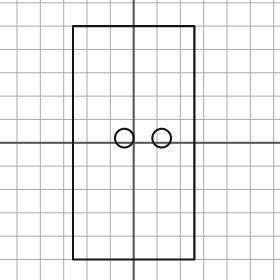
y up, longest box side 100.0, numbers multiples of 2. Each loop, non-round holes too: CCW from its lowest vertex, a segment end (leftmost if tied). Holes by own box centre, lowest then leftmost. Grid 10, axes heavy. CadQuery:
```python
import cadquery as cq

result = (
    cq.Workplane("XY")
    .moveTo(-26.0, -50.0)
    .lineTo(26.0, -50.0)
    .lineTo(26.0, 50.0)
    .lineTo(-26.0, 50.0)
    .close()
    .moveTo(-4.0, 2.0)
    .circle(4.0)
    .moveTo(12.0, 2.0)
    .circle(4.0)
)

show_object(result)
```